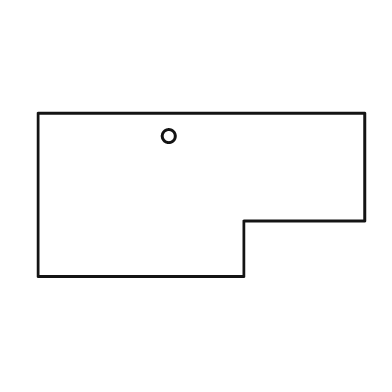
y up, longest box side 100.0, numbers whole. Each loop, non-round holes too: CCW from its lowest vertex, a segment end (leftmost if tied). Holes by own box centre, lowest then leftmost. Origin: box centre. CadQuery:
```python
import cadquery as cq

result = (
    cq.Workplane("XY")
    .moveTo(-50.0, -25.0)
    .lineTo(13.0, -25.0)
    .lineTo(13.0, -8.0)
    .lineTo(50.0, -8.0)
    .lineTo(50.0, 25.0)
    .lineTo(-50.0, 25.0)
    .close()
    .moveTo(-10.0, 18.0)
    .circle(2.0)
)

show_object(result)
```